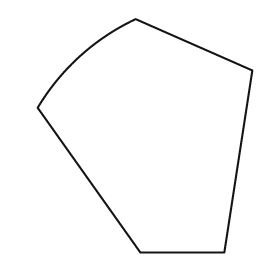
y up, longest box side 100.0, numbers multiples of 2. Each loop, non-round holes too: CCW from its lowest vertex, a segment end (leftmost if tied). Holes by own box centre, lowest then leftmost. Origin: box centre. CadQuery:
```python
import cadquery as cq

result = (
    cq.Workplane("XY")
    .moveTo(-2.0, -50.0)
    .lineTo(34.0, -50.0)
    .lineTo(46.0, 28.0)
    .lineTo(-4.0, 50.0)
    .threePointArc((-28.0, 34.0), (-46.0, 12.0))
    .close()
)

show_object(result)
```